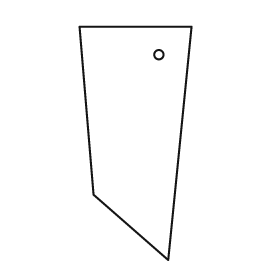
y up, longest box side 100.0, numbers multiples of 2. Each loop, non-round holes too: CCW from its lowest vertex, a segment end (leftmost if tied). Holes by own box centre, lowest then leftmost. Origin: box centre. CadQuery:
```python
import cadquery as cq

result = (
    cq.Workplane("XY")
    .moveTo(14.0, -50.0)
    .lineTo(24.0, 50.0)
    .lineTo(-24.0, 50.0)
    .lineTo(-18.0, -22.0)
    .close()
    .moveTo(10.0, 38.0)
    .circle(2.0)
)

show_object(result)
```